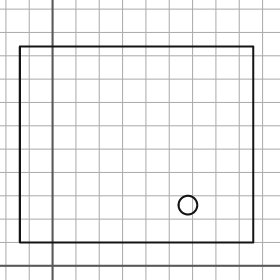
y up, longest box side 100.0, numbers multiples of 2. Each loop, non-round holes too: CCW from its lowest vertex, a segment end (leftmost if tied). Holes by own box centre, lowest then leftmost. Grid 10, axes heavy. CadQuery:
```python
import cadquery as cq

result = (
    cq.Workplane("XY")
    .moveTo(-14.0, 10.0)
    .lineTo(86.0, 10.0)
    .lineTo(86.0, 94.0)
    .lineTo(-14.0, 94.0)
    .close()
    .moveTo(58.0, 26.0)
    .circle(4.0)
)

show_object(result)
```